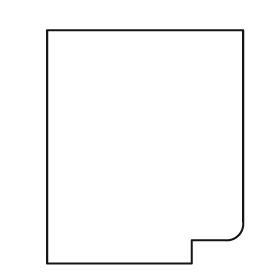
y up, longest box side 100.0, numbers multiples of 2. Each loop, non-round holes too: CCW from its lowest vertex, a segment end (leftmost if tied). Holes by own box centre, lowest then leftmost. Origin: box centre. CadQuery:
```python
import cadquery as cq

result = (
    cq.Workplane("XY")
    .moveTo(-42.0, -50.0)
    .lineTo(20.0, -50.0)
    .lineTo(20.0, -40.0)
    .lineTo(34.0, -40.0)
    .threePointArc((40.0, -38.0), (42.0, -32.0))
    .lineTo(42.0, 50.0)
    .lineTo(-42.0, 50.0)
    .close()
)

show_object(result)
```